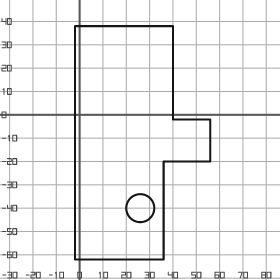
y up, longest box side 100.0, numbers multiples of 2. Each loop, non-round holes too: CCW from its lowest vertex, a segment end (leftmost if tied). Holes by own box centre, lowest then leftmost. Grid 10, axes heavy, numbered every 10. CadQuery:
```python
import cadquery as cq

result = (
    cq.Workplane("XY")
    .moveTo(-2.0, -62.0)
    .lineTo(36.0, -62.0)
    .lineTo(36.0, -20.0)
    .lineTo(56.0, -20.0)
    .lineTo(56.0, -2.0)
    .lineTo(40.0, -2.0)
    .lineTo(40.0, 38.0)
    .lineTo(-2.0, 38.0)
    .close()
    .moveTo(26.0, -40.0)
    .circle(6.0)
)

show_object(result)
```